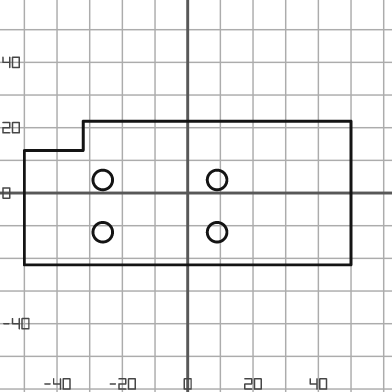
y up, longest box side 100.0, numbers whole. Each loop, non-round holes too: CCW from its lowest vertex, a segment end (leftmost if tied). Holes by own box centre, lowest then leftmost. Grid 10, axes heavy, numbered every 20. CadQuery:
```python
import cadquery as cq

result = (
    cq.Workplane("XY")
    .moveTo(-50.0, -22.0)
    .lineTo(50.0, -22.0)
    .lineTo(50.0, 22.0)
    .lineTo(-32.0, 22.0)
    .lineTo(-32.0, 13.0)
    .lineTo(-50.0, 13.0)
    .close()
    .moveTo(-26.0, -12.0)
    .circle(3.0)
    .moveTo(9.0, -12.0)
    .circle(3.0)
    .moveTo(-26.0, 4.0)
    .circle(3.0)
    .moveTo(9.0, 4.0)
    .circle(3.0)
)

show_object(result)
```